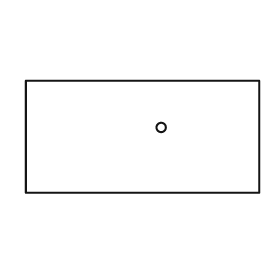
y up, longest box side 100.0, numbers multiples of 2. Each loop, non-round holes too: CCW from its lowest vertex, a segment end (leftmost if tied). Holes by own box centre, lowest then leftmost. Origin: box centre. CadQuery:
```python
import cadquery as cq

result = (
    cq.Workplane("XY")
    .moveTo(-50.0, -24.0)
    .lineTo(50.0, -24.0)
    .lineTo(50.0, 24.0)
    .lineTo(-50.0, 24.0)
    .close()
    .moveTo(8.0, 4.0)
    .circle(2.0)
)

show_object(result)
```